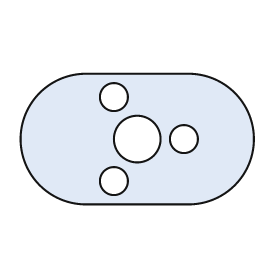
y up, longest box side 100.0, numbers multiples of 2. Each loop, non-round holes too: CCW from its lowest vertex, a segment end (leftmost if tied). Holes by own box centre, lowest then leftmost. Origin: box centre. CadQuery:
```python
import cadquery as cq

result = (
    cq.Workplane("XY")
    .moveTo(-22.0, -28.0)
    .lineTo(22.0, -28.0)
    .threePointArc((50.0, 0.0), (22.0, 28.0))
    .lineTo(-22.0, 28.0)
    .threePointArc((-50.0, 0.0), (-22.0, -28.0))
    .close()
    .moveTo(-10.0, -18.0)
    .circle(6.0)
    .moveTo(0.0, 0.0)
    .circle(10.0)
    .moveTo(20.0, 0.0)
    .circle(6.0)
    .moveTo(-10.0, 18.0)
    .circle(6.0)
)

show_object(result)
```